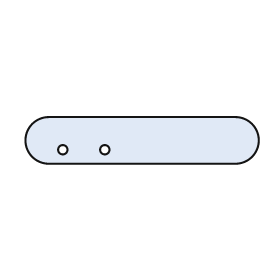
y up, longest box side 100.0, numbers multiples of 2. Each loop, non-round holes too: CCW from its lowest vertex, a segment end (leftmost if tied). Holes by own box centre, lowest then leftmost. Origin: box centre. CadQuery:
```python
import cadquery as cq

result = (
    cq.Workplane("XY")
    .moveTo(-40.0, -10.0)
    .lineTo(40.0, -10.0)
    .threePointArc((50.0, 0.0), (40.0, 10.0))
    .lineTo(-40.0, 10.0)
    .threePointArc((-50.0, 0.0), (-40.0, -10.0))
    .close()
    .moveTo(-34.0, -4.0)
    .circle(2.0)
    .moveTo(-16.0, -4.0)
    .circle(2.0)
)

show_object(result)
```